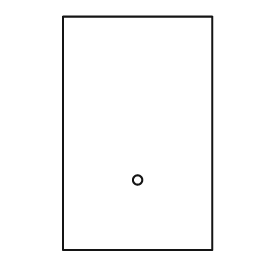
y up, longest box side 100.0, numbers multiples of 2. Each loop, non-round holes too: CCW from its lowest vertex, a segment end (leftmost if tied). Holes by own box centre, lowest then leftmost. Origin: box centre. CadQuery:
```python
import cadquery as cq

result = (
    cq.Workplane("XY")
    .moveTo(-32.0, -50.0)
    .lineTo(32.0, -50.0)
    .lineTo(32.0, 50.0)
    .lineTo(-32.0, 50.0)
    .close()
    .moveTo(0.0, -20.0)
    .circle(2.0)
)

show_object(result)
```